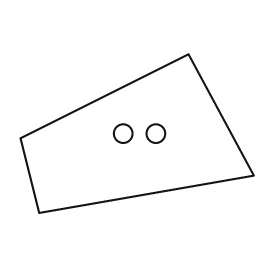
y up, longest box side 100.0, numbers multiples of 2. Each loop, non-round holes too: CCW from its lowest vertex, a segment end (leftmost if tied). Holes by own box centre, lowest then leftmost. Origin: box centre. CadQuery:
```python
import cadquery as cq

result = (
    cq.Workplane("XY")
    .moveTo(-42.0, -34.0)
    .lineTo(50.0, -18.0)
    .lineTo(22.0, 34.0)
    .lineTo(-50.0, -2.0)
    .close()
    .moveTo(-6.0, 0.0)
    .circle(4.0)
    .moveTo(8.0, 0.0)
    .circle(4.0)
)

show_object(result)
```